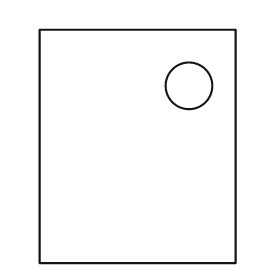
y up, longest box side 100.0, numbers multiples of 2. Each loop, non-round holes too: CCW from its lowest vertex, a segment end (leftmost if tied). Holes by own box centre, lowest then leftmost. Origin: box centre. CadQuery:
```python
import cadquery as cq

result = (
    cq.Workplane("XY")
    .moveTo(-42.0, -50.0)
    .lineTo(42.0, -50.0)
    .lineTo(42.0, 50.0)
    .lineTo(-42.0, 50.0)
    .close()
    .moveTo(22.0, 26.0)
    .circle(10.0)
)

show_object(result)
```